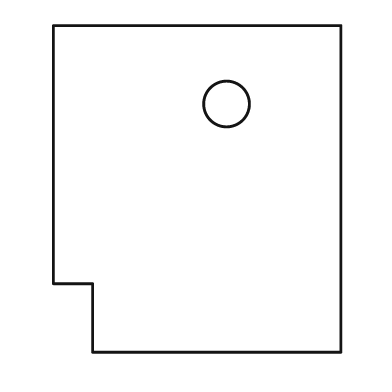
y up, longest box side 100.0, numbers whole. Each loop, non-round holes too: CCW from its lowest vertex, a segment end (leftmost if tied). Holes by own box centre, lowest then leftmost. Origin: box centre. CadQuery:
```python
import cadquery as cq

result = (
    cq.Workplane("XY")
    .moveTo(-32.0, -50.0)
    .lineTo(44.0, -50.0)
    .lineTo(44.0, 50.0)
    .lineTo(-44.0, 50.0)
    .lineTo(-44.0, -29.0)
    .lineTo(-32.0, -29.0)
    .close()
    .moveTo(9.0, 26.0)
    .circle(7.0)
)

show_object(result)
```